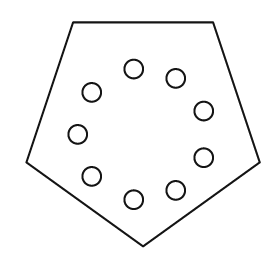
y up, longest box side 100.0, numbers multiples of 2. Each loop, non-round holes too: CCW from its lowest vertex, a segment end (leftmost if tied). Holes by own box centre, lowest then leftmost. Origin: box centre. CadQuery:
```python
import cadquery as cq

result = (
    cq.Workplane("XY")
    .moveTo(0.0, -48.0)
    .lineTo(50.0, -12.0)
    .lineTo(30.0, 48.0)
    .lineTo(-30.0, 48.0)
    .lineTo(-50.0, -12.0)
    .close()
    .moveTo(-4.0, -28.0)
    .circle(4.0)
    .moveTo(14.0, -24.0)
    .circle(4.0)
    .moveTo(-22.0, -18.0)
    .circle(4.0)
    .moveTo(26.0, -10.0)
    .circle(4.0)
    .moveTo(-28.0, 0.0)
    .circle(4.0)
    .moveTo(26.0, 10.0)
    .circle(4.0)
    .moveTo(-22.0, 18.0)
    .circle(4.0)
    .moveTo(14.0, 24.0)
    .circle(4.0)
    .moveTo(-4.0, 28.0)
    .circle(4.0)
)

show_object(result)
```